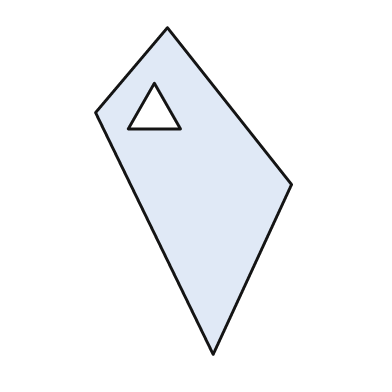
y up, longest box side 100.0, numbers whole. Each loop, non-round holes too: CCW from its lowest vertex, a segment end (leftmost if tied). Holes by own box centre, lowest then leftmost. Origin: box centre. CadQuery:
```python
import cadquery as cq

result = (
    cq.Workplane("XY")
    .moveTo(6.0, -50.0)
    .lineTo(30.0, 2.0)
    .lineTo(-8.0, 50.0)
    .lineTo(-30.0, 24.0)
    .close()
    .moveTo(-20.0, 19.0)
    .lineTo(-4.0, 19.0)
    .lineTo(-12.0, 33.0)
    .close()
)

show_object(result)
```